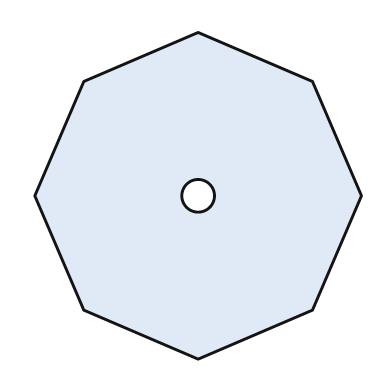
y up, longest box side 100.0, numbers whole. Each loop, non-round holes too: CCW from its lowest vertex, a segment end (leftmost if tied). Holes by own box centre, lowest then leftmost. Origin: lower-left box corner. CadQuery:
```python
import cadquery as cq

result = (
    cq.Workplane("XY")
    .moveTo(50.0, 0.0)
    .lineTo(85.0, 15.0)
    .lineTo(100.0, 50.0)
    .lineTo(85.0, 85.0)
    .lineTo(50.0, 100.0)
    .lineTo(15.0, 85.0)
    .lineTo(0.0, 50.0)
    .lineTo(15.0, 15.0)
    .close()
    .moveTo(50.0, 50.0)
    .circle(5.0)
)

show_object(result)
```